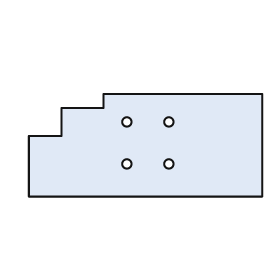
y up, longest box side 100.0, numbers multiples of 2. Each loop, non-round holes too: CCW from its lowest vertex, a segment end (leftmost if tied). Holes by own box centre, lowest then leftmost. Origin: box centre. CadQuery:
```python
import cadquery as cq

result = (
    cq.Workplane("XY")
    .moveTo(-50.0, -22.0)
    .lineTo(50.0, -22.0)
    .lineTo(50.0, 22.0)
    .lineTo(-18.0, 22.0)
    .lineTo(-18.0, 16.0)
    .lineTo(-36.0, 16.0)
    .lineTo(-36.0, 4.0)
    .lineTo(-50.0, 4.0)
    .close()
    .moveTo(-8.0, -8.0)
    .circle(2.0)
    .moveTo(10.0, -8.0)
    .circle(2.0)
    .moveTo(-8.0, 10.0)
    .circle(2.0)
    .moveTo(10.0, 10.0)
    .circle(2.0)
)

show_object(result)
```